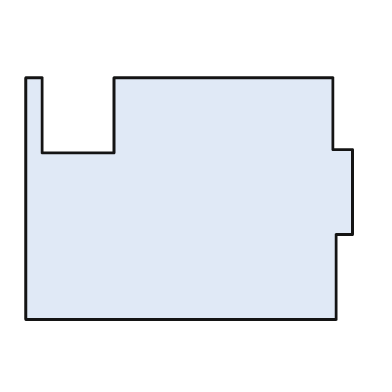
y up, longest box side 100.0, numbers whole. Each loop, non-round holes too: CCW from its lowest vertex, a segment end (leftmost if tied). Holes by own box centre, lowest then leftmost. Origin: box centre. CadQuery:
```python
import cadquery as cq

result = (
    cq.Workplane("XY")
    .moveTo(-50.0, -37.0)
    .lineTo(45.0, -37.0)
    .lineTo(45.0, -11.0)
    .lineTo(50.0, -11.0)
    .lineTo(50.0, 15.0)
    .lineTo(44.0, 15.0)
    .lineTo(44.0, 37.0)
    .lineTo(-23.0, 37.0)
    .lineTo(-23.0, 14.0)
    .lineTo(-45.0, 14.0)
    .lineTo(-45.0, 37.0)
    .lineTo(-50.0, 37.0)
    .close()
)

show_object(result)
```